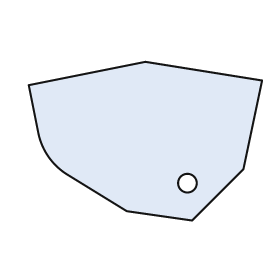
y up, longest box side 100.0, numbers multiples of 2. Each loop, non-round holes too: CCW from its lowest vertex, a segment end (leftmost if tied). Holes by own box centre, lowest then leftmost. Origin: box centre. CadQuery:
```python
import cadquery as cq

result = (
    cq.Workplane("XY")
    .moveTo(20.0, -34.0)
    .lineTo(42.0, -12.0)
    .lineTo(50.0, 26.0)
    .lineTo(0.0, 34.0)
    .lineTo(-50.0, 24.0)
    .lineTo(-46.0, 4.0)
    .threePointArc((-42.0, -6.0), (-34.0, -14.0))
    .lineTo(-8.0, -30.0)
    .close()
    .moveTo(18.0, -18.0)
    .circle(4.0)
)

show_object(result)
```